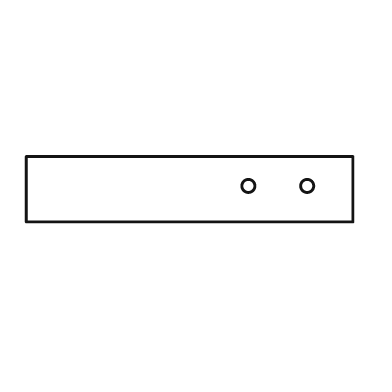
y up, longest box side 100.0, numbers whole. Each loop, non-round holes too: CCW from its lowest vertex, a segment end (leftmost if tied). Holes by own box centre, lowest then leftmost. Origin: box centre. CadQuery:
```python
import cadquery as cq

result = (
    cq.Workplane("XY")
    .moveTo(-50.0, -10.0)
    .lineTo(50.0, -10.0)
    .lineTo(50.0, 10.0)
    .lineTo(-50.0, 10.0)
    .close()
    .moveTo(18.0, 1.0)
    .circle(2.0)
    .moveTo(36.0, 1.0)
    .circle(2.0)
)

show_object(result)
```